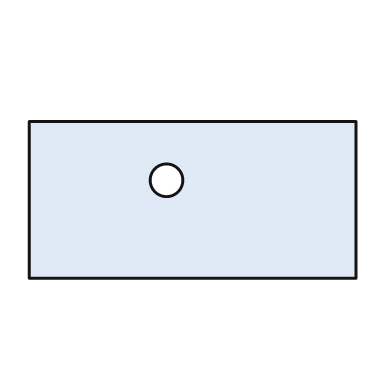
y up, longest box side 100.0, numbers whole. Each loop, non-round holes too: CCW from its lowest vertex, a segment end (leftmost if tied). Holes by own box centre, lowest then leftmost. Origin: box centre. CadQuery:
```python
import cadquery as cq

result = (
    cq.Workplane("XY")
    .moveTo(-50.0, -24.0)
    .lineTo(50.0, -24.0)
    .lineTo(50.0, 24.0)
    .lineTo(-50.0, 24.0)
    .close()
    .moveTo(-8.0, 6.0)
    .circle(5.0)
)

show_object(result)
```